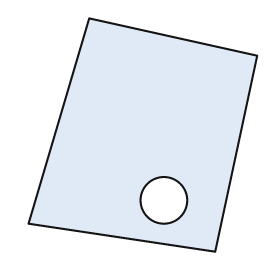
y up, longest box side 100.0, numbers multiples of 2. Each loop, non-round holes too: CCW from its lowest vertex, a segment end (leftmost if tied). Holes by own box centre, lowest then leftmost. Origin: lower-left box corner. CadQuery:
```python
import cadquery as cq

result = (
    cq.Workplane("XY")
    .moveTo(80.0, 0.0)
    .lineTo(98.0, 84.0)
    .lineTo(26.0, 100.0)
    .lineTo(0.0, 12.0)
    .close()
    .moveTo(58.0, 22.0)
    .circle(10.0)
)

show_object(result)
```